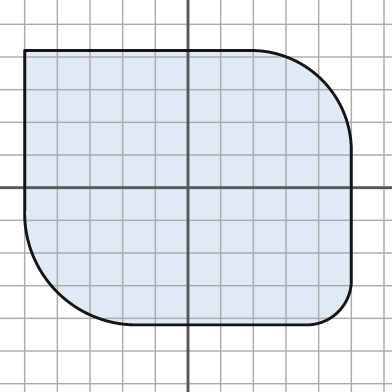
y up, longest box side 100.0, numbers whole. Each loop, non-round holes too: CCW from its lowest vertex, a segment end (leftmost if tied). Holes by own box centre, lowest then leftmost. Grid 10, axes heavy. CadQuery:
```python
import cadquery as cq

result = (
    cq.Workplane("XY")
    .moveTo(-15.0, -42.0)
    .lineTo(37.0, -42.0)
    .threePointArc((46.0, -38.0), (50.0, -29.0))
    .lineTo(50.0, 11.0)
    .threePointArc((41.0, 33.0), (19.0, 42.0))
    .lineTo(-50.0, 42.0)
    .lineTo(-50.0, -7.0)
    .threePointArc((-40.0, -32.0), (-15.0, -42.0))
    .close()
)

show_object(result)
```